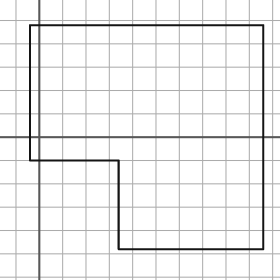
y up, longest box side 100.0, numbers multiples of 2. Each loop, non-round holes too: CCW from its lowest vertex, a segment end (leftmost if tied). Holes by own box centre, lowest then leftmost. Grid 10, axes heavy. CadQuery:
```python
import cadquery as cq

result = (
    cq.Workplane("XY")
    .moveTo(34.0, -48.0)
    .lineTo(96.0, -48.0)
    .lineTo(96.0, 48.0)
    .lineTo(-4.0, 48.0)
    .lineTo(-4.0, -10.0)
    .lineTo(34.0, -10.0)
    .close()
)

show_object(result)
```